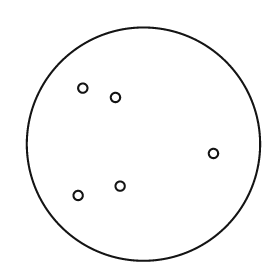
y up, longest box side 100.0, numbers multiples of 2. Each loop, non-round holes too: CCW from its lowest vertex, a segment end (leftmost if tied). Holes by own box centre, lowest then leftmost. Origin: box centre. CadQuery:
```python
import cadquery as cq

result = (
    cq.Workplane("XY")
    .moveTo(0.0, 0.0)
    .circle(50.0)
    .moveTo(-28.0, -22.0)
    .circle(2.0)
    .moveTo(-10.0, -18.0)
    .circle(2.0)
    .moveTo(30.0, -4.0)
    .circle(2.0)
    .moveTo(-12.0, 20.0)
    .circle(2.0)
    .moveTo(-26.0, 24.0)
    .circle(2.0)
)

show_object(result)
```